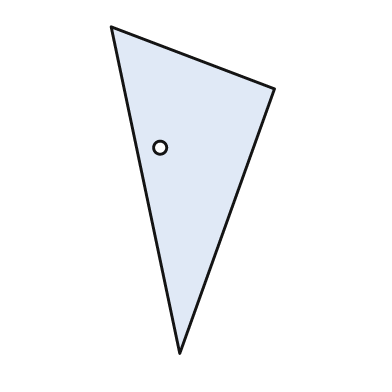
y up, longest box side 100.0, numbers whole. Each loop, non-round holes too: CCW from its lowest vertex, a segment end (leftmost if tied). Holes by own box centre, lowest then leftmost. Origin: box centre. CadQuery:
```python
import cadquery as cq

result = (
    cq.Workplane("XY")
    .moveTo(-4.0, -50.0)
    .lineTo(25.0, 31.0)
    .lineTo(-25.0, 50.0)
    .close()
    .moveTo(-10.0, 13.0)
    .circle(2.0)
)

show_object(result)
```